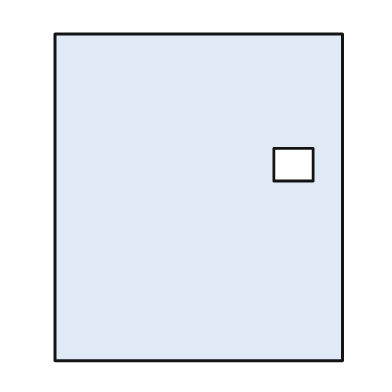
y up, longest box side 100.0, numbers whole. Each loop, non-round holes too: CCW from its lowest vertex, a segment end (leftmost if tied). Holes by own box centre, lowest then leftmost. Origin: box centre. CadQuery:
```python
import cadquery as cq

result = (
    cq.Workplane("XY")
    .moveTo(-44.0, -50.0)
    .lineTo(44.0, -50.0)
    .lineTo(44.0, 50.0)
    .lineTo(-44.0, 50.0)
    .close()
    .moveTo(23.0, 5.0)
    .lineTo(35.0, 5.0)
    .lineTo(35.0, 15.0)
    .lineTo(23.0, 15.0)
    .close()
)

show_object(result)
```